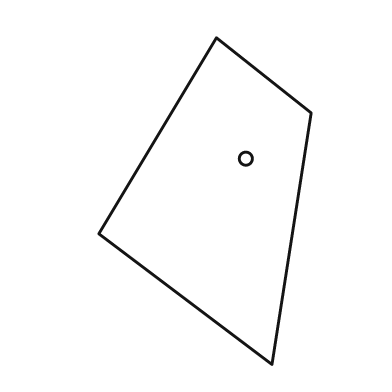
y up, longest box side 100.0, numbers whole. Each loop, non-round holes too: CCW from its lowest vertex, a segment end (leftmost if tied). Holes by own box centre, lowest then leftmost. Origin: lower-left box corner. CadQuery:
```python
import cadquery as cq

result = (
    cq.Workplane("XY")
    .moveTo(53.0, 0.0)
    .lineTo(65.0, 77.0)
    .lineTo(36.0, 100.0)
    .lineTo(0.0, 40.0)
    .close()
    .moveTo(45.0, 63.0)
    .circle(2.0)
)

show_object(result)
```